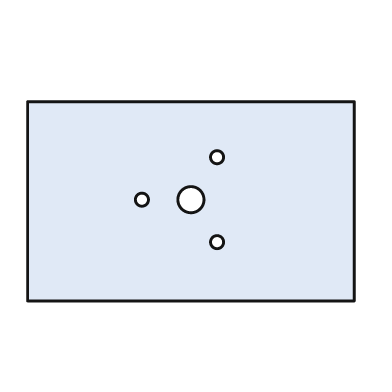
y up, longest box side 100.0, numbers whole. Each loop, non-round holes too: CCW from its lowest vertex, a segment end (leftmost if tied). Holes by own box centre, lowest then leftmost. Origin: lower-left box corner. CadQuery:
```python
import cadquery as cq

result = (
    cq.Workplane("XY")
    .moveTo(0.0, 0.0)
    .lineTo(100.0, 0.0)
    .lineTo(100.0, 61.0)
    .lineTo(0.0, 61.0)
    .close()
    .moveTo(58.0, 18.0)
    .circle(2.0)
    .moveTo(35.0, 31.0)
    .circle(2.0)
    .moveTo(50.0, 31.0)
    .circle(4.0)
    .moveTo(58.0, 44.0)
    .circle(2.0)
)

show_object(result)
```